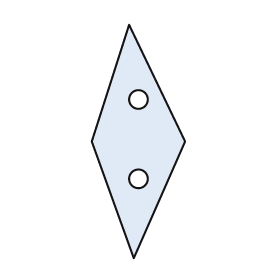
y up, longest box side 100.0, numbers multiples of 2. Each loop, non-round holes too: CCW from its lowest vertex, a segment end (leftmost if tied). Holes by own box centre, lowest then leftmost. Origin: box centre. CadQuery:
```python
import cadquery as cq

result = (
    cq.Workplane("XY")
    .moveTo(-2.0, -50.0)
    .lineTo(20.0, 0.0)
    .lineTo(-4.0, 50.0)
    .lineTo(-20.0, 0.0)
    .close()
    .moveTo(0.0, -16.0)
    .circle(4.0)
    .moveTo(0.0, 18.0)
    .circle(4.0)
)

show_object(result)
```